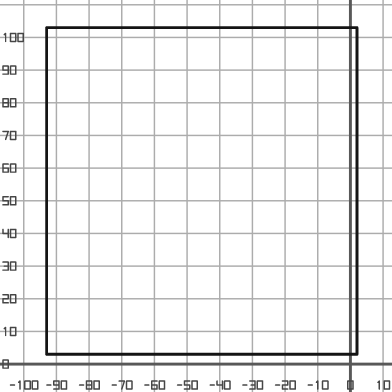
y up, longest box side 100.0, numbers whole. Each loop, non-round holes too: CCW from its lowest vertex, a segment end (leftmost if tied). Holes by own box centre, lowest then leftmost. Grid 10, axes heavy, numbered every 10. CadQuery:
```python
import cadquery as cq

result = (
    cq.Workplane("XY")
    .moveTo(-93.0, 3.0)
    .lineTo(2.0, 3.0)
    .lineTo(2.0, 103.0)
    .lineTo(-93.0, 103.0)
    .close()
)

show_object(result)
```